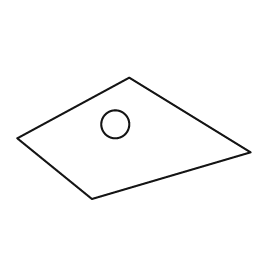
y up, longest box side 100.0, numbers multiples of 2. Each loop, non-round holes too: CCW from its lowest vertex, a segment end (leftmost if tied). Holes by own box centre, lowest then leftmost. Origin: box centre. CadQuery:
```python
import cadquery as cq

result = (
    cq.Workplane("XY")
    .moveTo(-18.0, -26.0)
    .lineTo(50.0, -6.0)
    .lineTo(-2.0, 26.0)
    .lineTo(-50.0, 0.0)
    .close()
    .moveTo(-8.0, 6.0)
    .circle(6.0)
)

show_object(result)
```